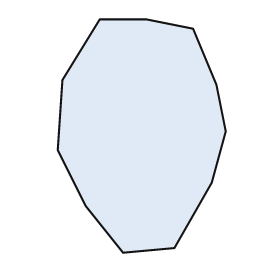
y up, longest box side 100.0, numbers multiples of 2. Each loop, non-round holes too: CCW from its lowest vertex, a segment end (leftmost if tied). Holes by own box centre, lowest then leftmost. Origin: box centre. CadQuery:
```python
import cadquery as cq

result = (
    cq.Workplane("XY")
    .moveTo(-8.0, -50.0)
    .lineTo(14.0, -48.0)
    .lineTo(30.0, -20.0)
    .lineTo(36.0, 2.0)
    .lineTo(32.0, 22.0)
    .lineTo(22.0, 46.0)
    .lineTo(2.0, 50.0)
    .lineTo(-18.0, 50.0)
    .lineTo(-34.0, 24.0)
    .lineTo(-36.0, -6.0)
    .lineTo(-24.0, -30.0)
    .close()
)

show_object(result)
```